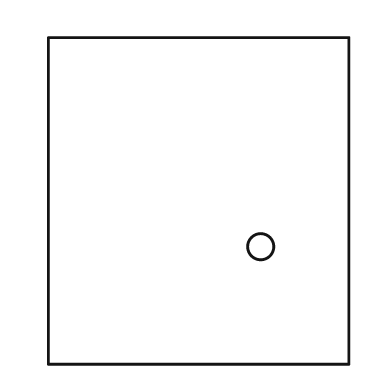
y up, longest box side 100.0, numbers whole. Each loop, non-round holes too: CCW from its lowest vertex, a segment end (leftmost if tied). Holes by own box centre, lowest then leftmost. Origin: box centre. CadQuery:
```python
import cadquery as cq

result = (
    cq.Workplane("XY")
    .moveTo(-46.0, -50.0)
    .lineTo(46.0, -50.0)
    .lineTo(46.0, 50.0)
    .lineTo(-46.0, 50.0)
    .close()
    .moveTo(19.0, -14.0)
    .circle(4.0)
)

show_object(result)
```